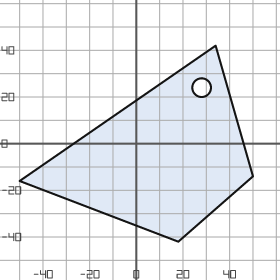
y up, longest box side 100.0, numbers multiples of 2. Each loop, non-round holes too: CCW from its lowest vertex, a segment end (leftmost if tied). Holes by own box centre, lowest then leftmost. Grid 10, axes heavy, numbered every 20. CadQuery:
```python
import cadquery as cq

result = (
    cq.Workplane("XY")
    .moveTo(18.0, -42.0)
    .lineTo(50.0, -14.0)
    .lineTo(34.0, 42.0)
    .lineTo(-50.0, -16.0)
    .close()
    .moveTo(28.0, 24.0)
    .circle(4.0)
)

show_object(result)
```